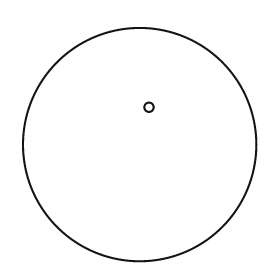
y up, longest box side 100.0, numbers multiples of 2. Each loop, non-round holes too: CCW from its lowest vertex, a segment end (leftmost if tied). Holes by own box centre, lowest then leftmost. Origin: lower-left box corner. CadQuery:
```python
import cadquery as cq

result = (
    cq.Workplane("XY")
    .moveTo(50.0, 50.0)
    .circle(50.0)
    .moveTo(54.0, 66.0)
    .circle(2.0)
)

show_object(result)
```